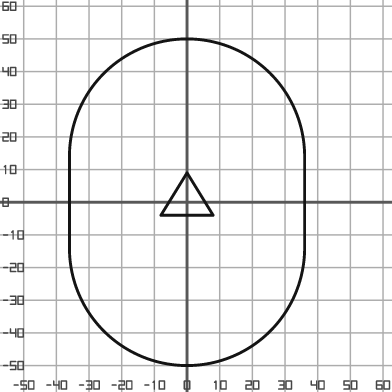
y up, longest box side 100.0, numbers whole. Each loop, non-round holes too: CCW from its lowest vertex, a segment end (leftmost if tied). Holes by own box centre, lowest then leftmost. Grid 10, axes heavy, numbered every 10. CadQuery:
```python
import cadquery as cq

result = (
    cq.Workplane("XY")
    .moveTo(-36.0, -14.0)
    .threePointArc((0.0, -50.0), (36.0, -14.0))
    .lineTo(36.0, 14.0)
    .threePointArc((0.0, 50.0), (-36.0, 14.0))
    .close()
    .moveTo(-8.0, -4.0)
    .lineTo(8.0, -4.0)
    .lineTo(0.0, 9.0)
    .close()
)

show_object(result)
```